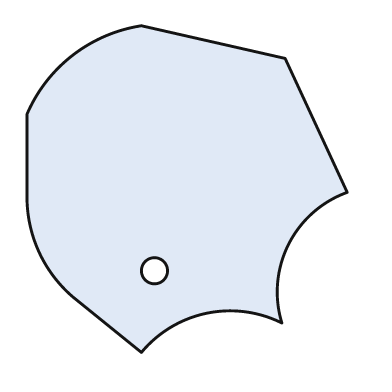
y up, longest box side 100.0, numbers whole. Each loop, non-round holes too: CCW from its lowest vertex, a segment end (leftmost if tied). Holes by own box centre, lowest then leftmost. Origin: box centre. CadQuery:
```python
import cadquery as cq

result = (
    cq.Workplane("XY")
    .moveTo(-14.0, -50.0)
    .threePointArc((6.0, -38.0), (29.0, -41.0))
    .threePointArc((31.0, -17.0), (49.0, -1.0))
    .lineTo(30.0, 40.0)
    .lineTo(-14.0, 50.0)
    .threePointArc((-35.0, 41.0), (-49.0, 23.0))
    .lineTo(-49.0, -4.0)
    .threePointArc((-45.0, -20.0), (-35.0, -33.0))
    .close()
    .moveTo(-10.0, -25.0)
    .circle(4.0)
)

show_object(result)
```